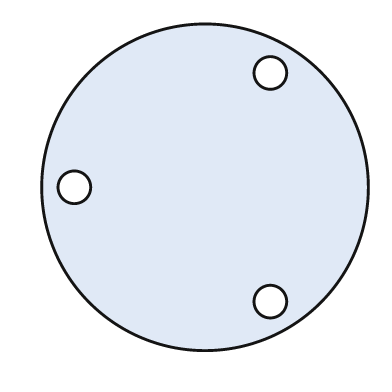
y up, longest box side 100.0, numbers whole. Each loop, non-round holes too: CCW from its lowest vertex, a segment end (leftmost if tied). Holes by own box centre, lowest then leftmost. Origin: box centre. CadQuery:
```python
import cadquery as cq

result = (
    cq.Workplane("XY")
    .moveTo(0.0, 0.0)
    .circle(50.0)
    .moveTo(20.0, -35.0)
    .circle(5.0)
    .moveTo(-40.0, 0.0)
    .circle(5.0)
    .moveTo(20.0, 35.0)
    .circle(5.0)
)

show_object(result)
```